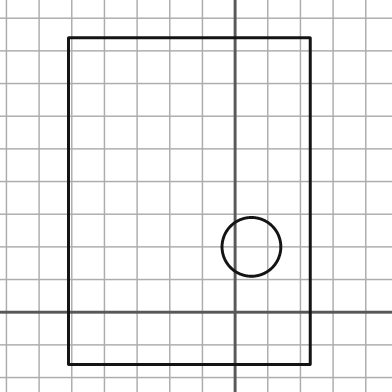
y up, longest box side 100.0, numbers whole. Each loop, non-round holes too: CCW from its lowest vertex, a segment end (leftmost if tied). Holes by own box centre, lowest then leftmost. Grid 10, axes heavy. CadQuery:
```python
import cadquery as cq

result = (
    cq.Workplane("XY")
    .moveTo(-51.0, -16.0)
    .lineTo(23.0, -16.0)
    .lineTo(23.0, 84.0)
    .lineTo(-51.0, 84.0)
    .close()
    .moveTo(5.0, 20.0)
    .circle(9.0)
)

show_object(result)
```